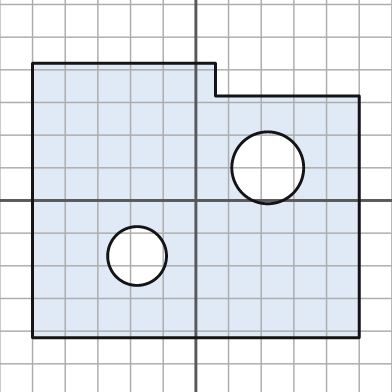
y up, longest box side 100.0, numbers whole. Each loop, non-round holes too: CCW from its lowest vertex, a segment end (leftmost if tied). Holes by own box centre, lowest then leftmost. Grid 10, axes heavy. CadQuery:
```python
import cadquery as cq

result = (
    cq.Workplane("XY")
    .moveTo(-50.0, -42.0)
    .lineTo(50.0, -42.0)
    .lineTo(50.0, 32.0)
    .lineTo(6.0, 32.0)
    .lineTo(6.0, 42.0)
    .lineTo(-50.0, 42.0)
    .close()
    .moveTo(-18.0, -17.0)
    .circle(9.0)
    .moveTo(22.0, 10.0)
    .circle(11.0)
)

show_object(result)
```